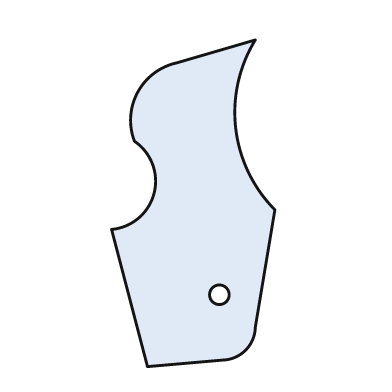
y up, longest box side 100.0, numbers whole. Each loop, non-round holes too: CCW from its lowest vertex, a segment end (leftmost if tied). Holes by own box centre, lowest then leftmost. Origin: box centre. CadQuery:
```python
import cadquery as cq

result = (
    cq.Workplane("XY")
    .moveTo(-14.0, -50.0)
    .lineTo(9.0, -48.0)
    .threePointArc((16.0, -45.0), (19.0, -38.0))
    .lineTo(25.0, -2.0)
    .threePointArc((13.0, 23.0), (19.0, 50.0))
    .lineTo(-5.0, 43.0)
    .threePointArc((-17.0, 34.0), (-18.0, 19.0))
    .threePointArc((-12.0, 3.0), (-25.0, -8.0))
    .close()
    .moveTo(8.0, -28.0)
    .circle(3.0)
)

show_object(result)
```